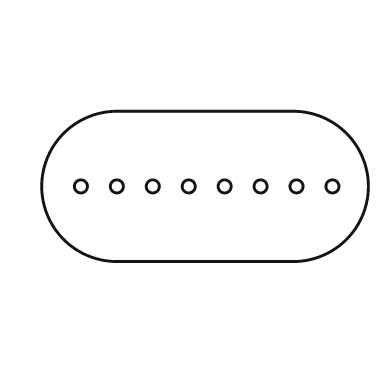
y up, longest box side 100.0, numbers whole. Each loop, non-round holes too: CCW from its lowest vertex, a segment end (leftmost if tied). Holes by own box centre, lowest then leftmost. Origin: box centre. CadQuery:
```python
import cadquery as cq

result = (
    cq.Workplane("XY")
    .moveTo(-27.0, -23.0)
    .lineTo(27.0, -23.0)
    .threePointArc((50.0, 0.0), (27.0, 23.0))
    .lineTo(-27.0, 23.0)
    .threePointArc((-50.0, 0.0), (-27.0, -23.0))
    .close()
    .moveTo(-38.0, 0.0)
    .circle(2.0)
    .moveTo(-27.0, 0.0)
    .circle(2.0)
    .moveTo(-16.0, 0.0)
    .circle(2.0)
    .moveTo(-5.0, 0.0)
    .circle(2.0)
    .moveTo(6.0, 0.0)
    .circle(2.0)
    .moveTo(17.0, 0.0)
    .circle(2.0)
    .moveTo(28.0, 0.0)
    .circle(2.0)
    .moveTo(39.0, 0.0)
    .circle(2.0)
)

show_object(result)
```